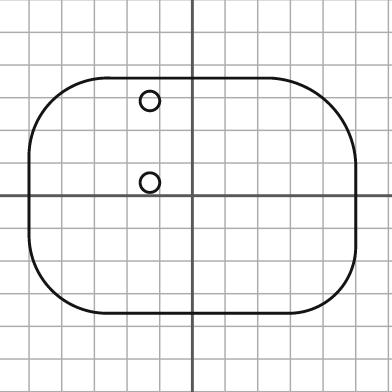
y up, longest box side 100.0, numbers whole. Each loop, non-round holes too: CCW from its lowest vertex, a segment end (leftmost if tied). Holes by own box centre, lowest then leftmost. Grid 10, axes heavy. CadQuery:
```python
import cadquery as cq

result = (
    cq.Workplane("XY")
    .moveTo(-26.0, -36.0)
    .lineTo(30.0, -36.0)
    .threePointArc((44.0, -30.0), (50.0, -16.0))
    .lineTo(50.0, 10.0)
    .threePointArc((42.0, 28.0), (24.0, 36.0))
    .lineTo(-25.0, 36.0)
    .threePointArc((-43.0, 29.0), (-50.0, 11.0))
    .lineTo(-50.0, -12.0)
    .threePointArc((-43.0, -29.0), (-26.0, -36.0))
    .close()
    .moveTo(-13.0, 4.0)
    .circle(3.0)
    .moveTo(-13.0, 29.0)
    .circle(3.0)
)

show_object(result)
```